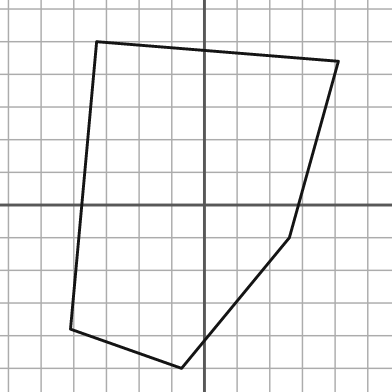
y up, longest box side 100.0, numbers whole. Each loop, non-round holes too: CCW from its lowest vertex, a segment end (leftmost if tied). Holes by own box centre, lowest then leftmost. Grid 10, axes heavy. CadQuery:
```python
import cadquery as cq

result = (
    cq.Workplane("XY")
    .moveTo(-7.0, -50.0)
    .lineTo(26.0, -10.0)
    .lineTo(41.0, 44.0)
    .lineTo(-33.0, 50.0)
    .lineTo(-41.0, -38.0)
    .close()
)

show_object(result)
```